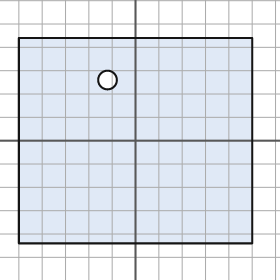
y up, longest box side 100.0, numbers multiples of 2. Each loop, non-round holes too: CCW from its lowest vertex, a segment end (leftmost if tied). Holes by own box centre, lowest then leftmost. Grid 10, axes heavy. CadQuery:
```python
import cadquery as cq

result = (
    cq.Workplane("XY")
    .moveTo(-50.0, -44.0)
    .lineTo(50.0, -44.0)
    .lineTo(50.0, 44.0)
    .lineTo(-50.0, 44.0)
    .close()
    .moveTo(-12.0, 26.0)
    .circle(4.0)
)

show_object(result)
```